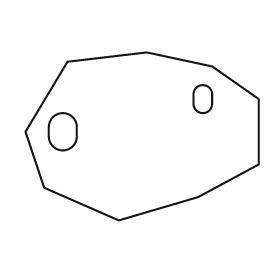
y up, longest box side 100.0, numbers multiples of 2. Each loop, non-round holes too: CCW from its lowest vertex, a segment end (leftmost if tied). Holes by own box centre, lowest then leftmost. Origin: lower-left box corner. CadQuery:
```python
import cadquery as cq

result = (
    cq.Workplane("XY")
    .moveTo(40.0, 0.0)
    .lineTo(74.0, 10.0)
    .lineTo(100.0, 24.0)
    .lineTo(100.0, 52.0)
    .lineTo(80.0, 66.0)
    .lineTo(52.0, 72.0)
    .lineTo(18.0, 68.0)
    .lineTo(0.0, 38.0)
    .lineTo(8.0, 14.0)
    .close()
    .moveTo(10.0, 36.0)
    .threePointArc((16.0, 30.0), (22.0, 36.0))
    .lineTo(22.0, 40.0)
    .threePointArc((16.0, 46.0), (10.0, 40.0))
    .close()
    .moveTo(72.0, 50.0)
    .threePointArc((76.0, 46.0), (80.0, 50.0))
    .lineTo(80.0, 54.0)
    .threePointArc((76.0, 58.0), (72.0, 54.0))
    .close()
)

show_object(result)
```